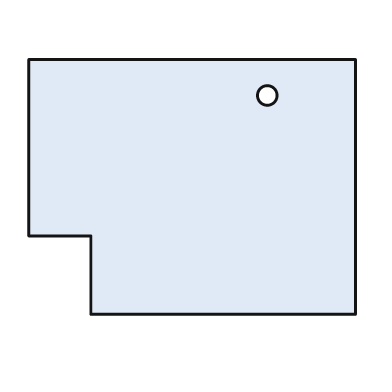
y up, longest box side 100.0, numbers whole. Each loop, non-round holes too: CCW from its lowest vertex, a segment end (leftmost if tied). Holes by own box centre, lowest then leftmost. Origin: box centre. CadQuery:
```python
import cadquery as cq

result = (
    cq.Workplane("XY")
    .moveTo(-31.0, -39.0)
    .lineTo(50.0, -39.0)
    .lineTo(50.0, 39.0)
    .lineTo(-50.0, 39.0)
    .lineTo(-50.0, -15.0)
    .lineTo(-31.0, -15.0)
    .close()
    .moveTo(23.0, 28.0)
    .circle(3.0)
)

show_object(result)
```